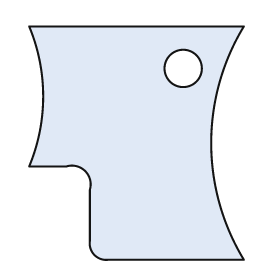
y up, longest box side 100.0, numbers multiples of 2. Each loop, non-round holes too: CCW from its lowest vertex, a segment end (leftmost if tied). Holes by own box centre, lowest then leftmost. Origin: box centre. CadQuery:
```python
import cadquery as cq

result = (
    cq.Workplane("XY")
    .moveTo(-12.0, -50.0)
    .lineTo(46.0, -50.0)
    .threePointArc((32.0, 0.0), (46.0, 50.0))
    .lineTo(-46.0, 50.0)
    .threePointArc((-40.0, 20.0), (-46.0, -10.0))
    .lineTo(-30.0, -10.0)
    .threePointArc((-22.0, -12.0), (-20.0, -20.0))
    .lineTo(-20.0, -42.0)
    .threePointArc((-18.0, -48.0), (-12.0, -50.0))
    .close()
    .moveTo(20.0, 32.0)
    .circle(8.0)
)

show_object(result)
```